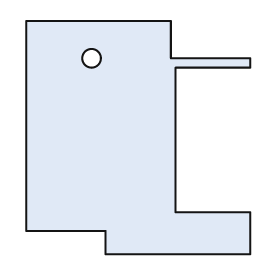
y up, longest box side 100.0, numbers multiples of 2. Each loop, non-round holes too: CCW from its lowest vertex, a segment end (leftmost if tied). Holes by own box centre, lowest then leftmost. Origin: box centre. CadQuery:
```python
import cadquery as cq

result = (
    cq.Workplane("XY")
    .moveTo(-14.0, -50.0)
    .lineTo(48.0, -50.0)
    .lineTo(48.0, -32.0)
    .lineTo(16.0, -32.0)
    .lineTo(16.0, 30.0)
    .lineTo(48.0, 30.0)
    .lineTo(48.0, 34.0)
    .lineTo(14.0, 34.0)
    .lineTo(14.0, 50.0)
    .lineTo(-48.0, 50.0)
    .lineTo(-48.0, -40.0)
    .lineTo(-14.0, -40.0)
    .close()
    .moveTo(-20.0, 34.0)
    .circle(4.0)
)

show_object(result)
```